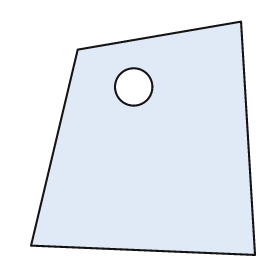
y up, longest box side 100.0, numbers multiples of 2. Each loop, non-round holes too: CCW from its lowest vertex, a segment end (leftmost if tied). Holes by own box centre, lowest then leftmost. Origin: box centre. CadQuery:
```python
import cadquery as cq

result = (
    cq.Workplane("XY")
    .moveTo(48.0, -50.0)
    .lineTo(42.0, 50.0)
    .lineTo(-28.0, 38.0)
    .lineTo(-48.0, -46.0)
    .close()
    .moveTo(-4.0, 22.0)
    .circle(8.0)
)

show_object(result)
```